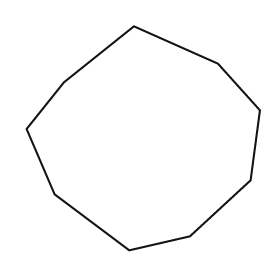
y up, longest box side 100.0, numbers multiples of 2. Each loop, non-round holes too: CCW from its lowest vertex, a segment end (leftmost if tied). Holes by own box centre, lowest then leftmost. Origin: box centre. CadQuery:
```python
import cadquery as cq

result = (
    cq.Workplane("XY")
    .moveTo(-6.0, -48.0)
    .lineTo(20.0, -42.0)
    .lineTo(46.0, -18.0)
    .lineTo(50.0, 12.0)
    .lineTo(32.0, 32.0)
    .lineTo(-4.0, 48.0)
    .lineTo(-34.0, 24.0)
    .lineTo(-50.0, 4.0)
    .lineTo(-38.0, -24.0)
    .close()
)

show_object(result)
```